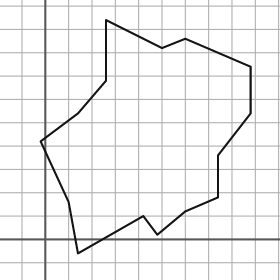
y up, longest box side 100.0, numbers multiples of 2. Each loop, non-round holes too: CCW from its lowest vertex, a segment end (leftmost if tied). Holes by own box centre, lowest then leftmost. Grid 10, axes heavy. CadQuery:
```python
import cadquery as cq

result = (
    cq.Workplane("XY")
    .moveTo(14.0, -6.0)
    .lineTo(42.0, 10.0)
    .lineTo(48.0, 2.0)
    .lineTo(60.0, 12.0)
    .lineTo(74.0, 18.0)
    .lineTo(74.0, 36.0)
    .lineTo(88.0, 54.0)
    .lineTo(88.0, 74.0)
    .lineTo(60.0, 86.0)
    .lineTo(50.0, 82.0)
    .lineTo(26.0, 94.0)
    .lineTo(26.0, 68.0)
    .lineTo(14.0, 54.0)
    .lineTo(-2.0, 42.0)
    .lineTo(10.0, 16.0)
    .close()
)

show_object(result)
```